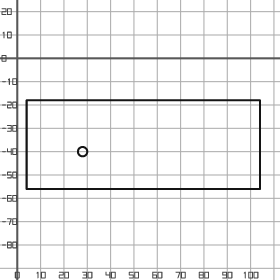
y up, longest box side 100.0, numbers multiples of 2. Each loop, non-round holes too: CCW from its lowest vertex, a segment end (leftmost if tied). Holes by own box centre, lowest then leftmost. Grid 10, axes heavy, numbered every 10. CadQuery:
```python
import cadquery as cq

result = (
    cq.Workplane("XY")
    .moveTo(4.0, -56.0)
    .lineTo(104.0, -56.0)
    .lineTo(104.0, -18.0)
    .lineTo(4.0, -18.0)
    .close()
    .moveTo(28.0, -40.0)
    .circle(2.0)
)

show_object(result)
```